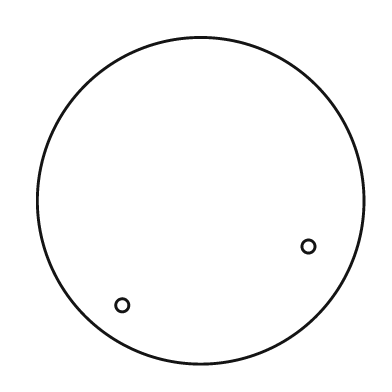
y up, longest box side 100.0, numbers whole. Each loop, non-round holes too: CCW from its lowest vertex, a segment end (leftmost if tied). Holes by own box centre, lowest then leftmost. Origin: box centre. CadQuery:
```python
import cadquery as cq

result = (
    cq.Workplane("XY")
    .moveTo(0.0, 0.0)
    .circle(50.0)
    .moveTo(-24.0, -32.0)
    .circle(2.0)
    .moveTo(33.0, -14.0)
    .circle(2.0)
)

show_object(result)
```